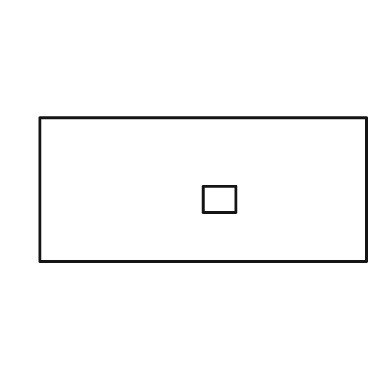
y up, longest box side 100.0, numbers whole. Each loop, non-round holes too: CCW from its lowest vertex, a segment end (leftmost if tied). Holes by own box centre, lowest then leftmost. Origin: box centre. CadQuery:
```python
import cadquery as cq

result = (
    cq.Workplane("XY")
    .moveTo(-50.0, -22.0)
    .lineTo(50.0, -22.0)
    .lineTo(50.0, 22.0)
    .lineTo(-50.0, 22.0)
    .close()
    .moveTo(0.0, -7.0)
    .lineTo(10.0, -7.0)
    .lineTo(10.0, 1.0)
    .lineTo(0.0, 1.0)
    .close()
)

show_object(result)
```